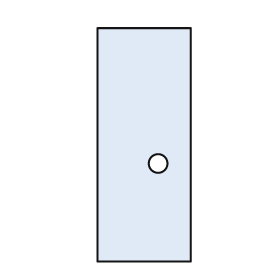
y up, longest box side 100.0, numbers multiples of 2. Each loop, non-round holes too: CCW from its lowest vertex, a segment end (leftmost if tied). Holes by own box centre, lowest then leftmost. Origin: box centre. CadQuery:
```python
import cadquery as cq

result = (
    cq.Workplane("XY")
    .moveTo(-20.0, -50.0)
    .lineTo(20.0, -50.0)
    .lineTo(20.0, 50.0)
    .lineTo(-20.0, 50.0)
    .close()
    .moveTo(6.0, -8.0)
    .circle(4.0)
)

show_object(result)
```